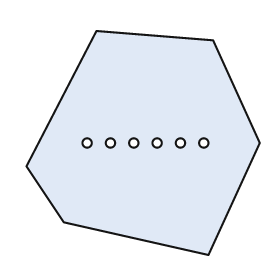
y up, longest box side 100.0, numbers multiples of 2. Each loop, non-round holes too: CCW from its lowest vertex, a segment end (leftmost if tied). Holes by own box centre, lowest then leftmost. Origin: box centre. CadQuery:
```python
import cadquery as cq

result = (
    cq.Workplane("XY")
    .moveTo(28.0, -48.0)
    .lineTo(50.0, 0.0)
    .lineTo(30.0, 44.0)
    .lineTo(-20.0, 48.0)
    .lineTo(-50.0, -10.0)
    .lineTo(-34.0, -34.0)
    .close()
    .moveTo(-24.0, 0.0)
    .circle(2.0)
    .moveTo(-14.0, 0.0)
    .circle(2.0)
    .moveTo(-4.0, 0.0)
    .circle(2.0)
    .moveTo(6.0, 0.0)
    .circle(2.0)
    .moveTo(16.0, 0.0)
    .circle(2.0)
    .moveTo(26.0, 0.0)
    .circle(2.0)
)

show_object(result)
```